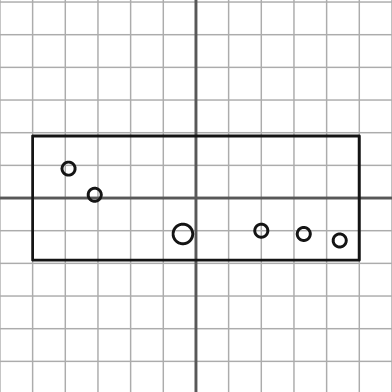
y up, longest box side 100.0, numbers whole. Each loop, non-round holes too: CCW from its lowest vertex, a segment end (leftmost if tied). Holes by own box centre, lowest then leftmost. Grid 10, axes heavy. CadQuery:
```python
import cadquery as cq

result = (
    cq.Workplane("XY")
    .moveTo(-50.0, -19.0)
    .lineTo(50.0, -19.0)
    .lineTo(50.0, 19.0)
    .lineTo(-50.0, 19.0)
    .close()
    .moveTo(44.0, -13.0)
    .circle(2.0)
    .moveTo(-4.0, -11.0)
    .circle(3.0)
    .moveTo(33.0, -11.0)
    .circle(2.0)
    .moveTo(20.0, -10.0)
    .circle(2.0)
    .moveTo(-31.0, 1.0)
    .circle(2.0)
    .moveTo(-39.0, 9.0)
    .circle(2.0)
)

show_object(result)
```